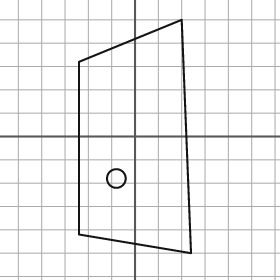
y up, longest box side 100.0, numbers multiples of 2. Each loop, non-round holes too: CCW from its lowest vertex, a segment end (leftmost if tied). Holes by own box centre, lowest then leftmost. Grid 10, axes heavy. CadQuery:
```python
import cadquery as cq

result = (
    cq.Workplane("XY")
    .moveTo(24.0, -50.0)
    .lineTo(20.0, 50.0)
    .lineTo(-24.0, 32.0)
    .lineTo(-24.0, -42.0)
    .close()
    .moveTo(-8.0, -18.0)
    .circle(4.0)
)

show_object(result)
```